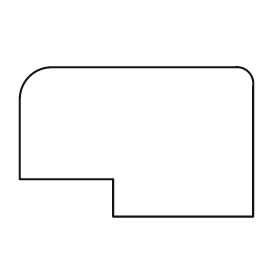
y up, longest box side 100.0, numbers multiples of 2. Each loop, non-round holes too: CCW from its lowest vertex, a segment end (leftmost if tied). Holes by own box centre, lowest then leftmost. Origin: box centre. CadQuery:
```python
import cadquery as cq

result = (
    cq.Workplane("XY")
    .moveTo(-10.0, -32.0)
    .lineTo(50.0, -32.0)
    .lineTo(50.0, 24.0)
    .threePointArc((48.0, 30.0), (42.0, 32.0))
    .lineTo(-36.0, 32.0)
    .threePointArc((-46.0, 28.0), (-50.0, 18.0))
    .lineTo(-50.0, -16.0)
    .lineTo(-10.0, -16.0)
    .close()
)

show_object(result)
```